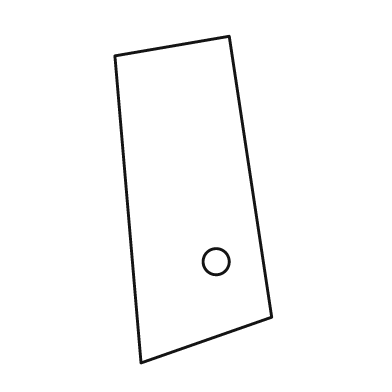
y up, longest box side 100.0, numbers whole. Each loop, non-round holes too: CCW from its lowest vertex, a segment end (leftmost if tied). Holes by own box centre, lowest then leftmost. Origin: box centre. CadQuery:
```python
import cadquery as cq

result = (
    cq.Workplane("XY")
    .moveTo(-16.0, -50.0)
    .lineTo(24.0, -36.0)
    .lineTo(11.0, 50.0)
    .lineTo(-24.0, 44.0)
    .close()
    .moveTo(7.0, -19.0)
    .circle(4.0)
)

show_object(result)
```